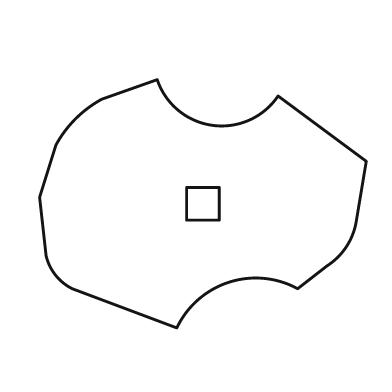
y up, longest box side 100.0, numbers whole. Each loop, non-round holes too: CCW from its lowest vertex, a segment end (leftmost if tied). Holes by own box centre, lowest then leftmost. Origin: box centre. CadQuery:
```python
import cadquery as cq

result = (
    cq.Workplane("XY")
    .moveTo(-8.0, -38.0)
    .threePointArc((8.0, -24.0), (29.0, -26.0))
    .lineTo(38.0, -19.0)
    .threePointArc((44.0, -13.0), (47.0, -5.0))
    .lineTo(50.0, 13.0)
    .lineTo(23.0, 33.0)
    .threePointArc((3.0, 24.0), (-14.0, 38.0))
    .lineTo(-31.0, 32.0)
    .threePointArc((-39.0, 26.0), (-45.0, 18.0))
    .lineTo(-50.0, 2.0)
    .lineTo(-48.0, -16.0)
    .threePointArc((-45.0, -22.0), (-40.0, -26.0))
    .close()
    .moveTo(-5.0, -5.0)
    .lineTo(5.0, -5.0)
    .lineTo(5.0, 5.0)
    .lineTo(-5.0, 5.0)
    .close()
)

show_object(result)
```